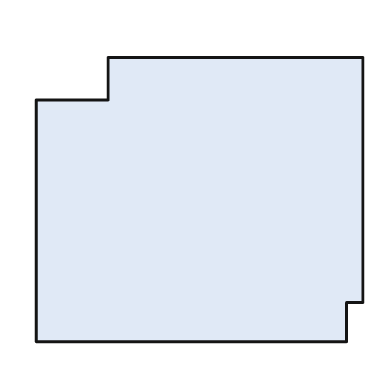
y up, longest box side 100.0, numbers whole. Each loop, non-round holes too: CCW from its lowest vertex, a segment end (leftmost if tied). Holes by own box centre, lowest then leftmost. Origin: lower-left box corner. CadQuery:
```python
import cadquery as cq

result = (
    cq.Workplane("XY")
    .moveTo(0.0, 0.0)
    .lineTo(95.0, 0.0)
    .lineTo(95.0, 12.0)
    .lineTo(100.0, 12.0)
    .lineTo(100.0, 87.0)
    .lineTo(22.0, 87.0)
    .lineTo(22.0, 74.0)
    .lineTo(0.0, 74.0)
    .close()
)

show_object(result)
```